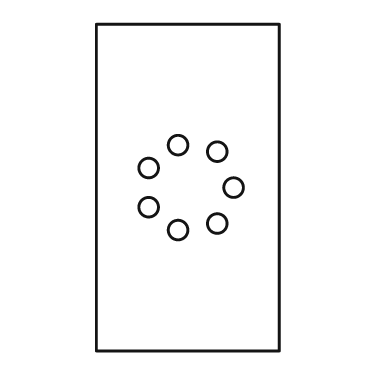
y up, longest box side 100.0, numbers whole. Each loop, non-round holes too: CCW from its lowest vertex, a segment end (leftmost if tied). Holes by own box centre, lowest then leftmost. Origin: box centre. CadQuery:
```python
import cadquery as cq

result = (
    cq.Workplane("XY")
    .moveTo(-28.0, -50.0)
    .lineTo(28.0, -50.0)
    .lineTo(28.0, 50.0)
    .lineTo(-28.0, 50.0)
    .close()
    .moveTo(-3.0, -13.0)
    .circle(3.0)
    .moveTo(9.0, -11.0)
    .circle(3.0)
    .moveTo(-12.0, -6.0)
    .circle(3.0)
    .moveTo(14.0, 0.0)
    .circle(3.0)
    .moveTo(-12.0, 6.0)
    .circle(3.0)
    .moveTo(9.0, 11.0)
    .circle(3.0)
    .moveTo(-3.0, 13.0)
    .circle(3.0)
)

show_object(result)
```